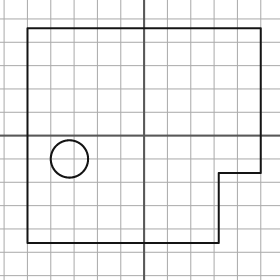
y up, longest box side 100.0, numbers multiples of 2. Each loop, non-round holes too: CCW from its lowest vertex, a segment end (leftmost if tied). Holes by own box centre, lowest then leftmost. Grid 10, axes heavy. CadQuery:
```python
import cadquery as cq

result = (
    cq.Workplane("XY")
    .moveTo(-50.0, -46.0)
    .lineTo(32.0, -46.0)
    .lineTo(32.0, -16.0)
    .lineTo(50.0, -16.0)
    .lineTo(50.0, 46.0)
    .lineTo(-50.0, 46.0)
    .close()
    .moveTo(-32.0, -10.0)
    .circle(8.0)
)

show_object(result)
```